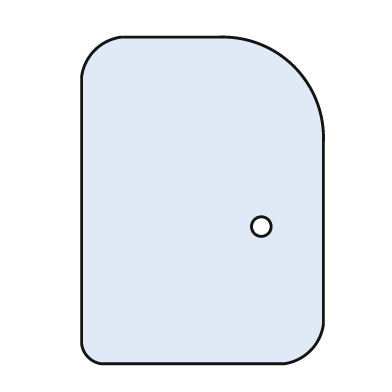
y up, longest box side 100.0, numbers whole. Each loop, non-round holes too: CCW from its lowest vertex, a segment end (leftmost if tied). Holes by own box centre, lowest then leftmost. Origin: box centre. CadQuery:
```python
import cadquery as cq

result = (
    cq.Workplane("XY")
    .moveTo(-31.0, -50.0)
    .lineTo(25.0, -50.0)
    .threePointArc((33.0, -46.0), (37.0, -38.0))
    .lineTo(37.0, 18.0)
    .threePointArc((28.0, 41.0), (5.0, 50.0))
    .lineTo(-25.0, 50.0)
    .threePointArc((-33.0, 46.0), (-37.0, 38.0))
    .lineTo(-37.0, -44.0)
    .threePointArc((-35.0, -48.0), (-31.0, -50.0))
    .close()
    .moveTo(18.0, -8.0)
    .circle(3.0)
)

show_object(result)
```